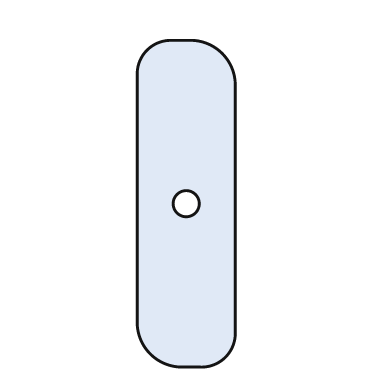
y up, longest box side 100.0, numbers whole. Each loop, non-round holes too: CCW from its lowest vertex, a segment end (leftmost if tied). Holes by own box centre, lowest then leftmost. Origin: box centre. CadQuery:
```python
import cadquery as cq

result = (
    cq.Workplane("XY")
    .moveTo(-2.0, -50.0)
    .lineTo(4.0, -50.0)
    .threePointArc((12.0, -47.0), (15.0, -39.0))
    .lineTo(15.0, 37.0)
    .threePointArc((11.0, 46.0), (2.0, 50.0))
    .lineTo(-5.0, 50.0)
    .threePointArc((-12.0, 47.0), (-15.0, 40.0))
    .lineTo(-15.0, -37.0)
    .threePointArc((-11.0, -46.0), (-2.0, -50.0))
    .close()
    .moveTo(0.0, 0.0)
    .circle(4.0)
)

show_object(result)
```